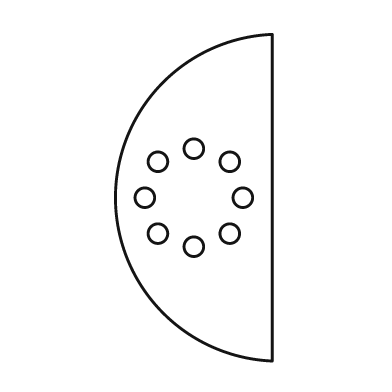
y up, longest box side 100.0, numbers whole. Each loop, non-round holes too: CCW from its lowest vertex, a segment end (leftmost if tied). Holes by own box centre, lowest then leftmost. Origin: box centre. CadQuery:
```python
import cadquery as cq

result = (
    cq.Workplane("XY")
    .moveTo(24.0, -50.0)
    .lineTo(24.0, 50.0)
    .threePointArc((-24.0, 0.0), (24.0, -50.0))
    .close()
    .moveTo(0.0, -15.0)
    .circle(3.0)
    .moveTo(-11.0, -11.0)
    .circle(3.0)
    .moveTo(11.0, -11.0)
    .circle(3.0)
    .moveTo(-15.0, 0.0)
    .circle(3.0)
    .moveTo(15.0, 0.0)
    .circle(3.0)
    .moveTo(-11.0, 11.0)
    .circle(3.0)
    .moveTo(11.0, 11.0)
    .circle(3.0)
    .moveTo(0.0, 15.0)
    .circle(3.0)
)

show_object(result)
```